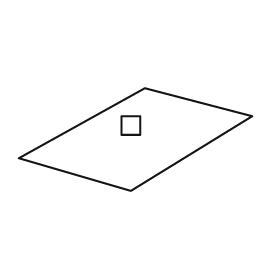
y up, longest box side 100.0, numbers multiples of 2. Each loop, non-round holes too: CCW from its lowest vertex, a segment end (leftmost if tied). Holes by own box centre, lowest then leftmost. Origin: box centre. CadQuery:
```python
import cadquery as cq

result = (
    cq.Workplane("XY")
    .moveTo(-2.0, -22.0)
    .lineTo(50.0, 10.0)
    .lineTo(4.0, 22.0)
    .lineTo(-50.0, -8.0)
    .close()
    .moveTo(-6.0, 2.0)
    .lineTo(2.0, 2.0)
    .lineTo(2.0, 10.0)
    .lineTo(-6.0, 10.0)
    .close()
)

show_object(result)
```